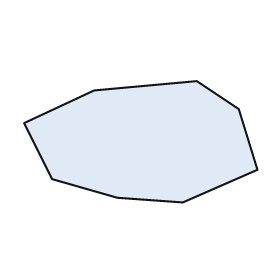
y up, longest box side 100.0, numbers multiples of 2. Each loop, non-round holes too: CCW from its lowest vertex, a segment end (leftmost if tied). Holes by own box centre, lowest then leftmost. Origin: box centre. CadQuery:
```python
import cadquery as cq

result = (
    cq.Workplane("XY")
    .moveTo(18.0, -26.0)
    .lineTo(50.0, -12.0)
    .lineTo(42.0, 14.0)
    .lineTo(24.0, 26.0)
    .lineTo(-20.0, 22.0)
    .lineTo(-50.0, 8.0)
    .lineTo(-38.0, -16.0)
    .lineTo(-10.0, -24.0)
    .close()
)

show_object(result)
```